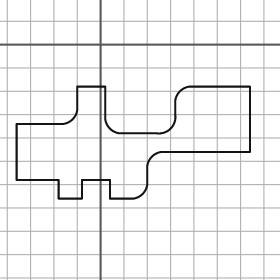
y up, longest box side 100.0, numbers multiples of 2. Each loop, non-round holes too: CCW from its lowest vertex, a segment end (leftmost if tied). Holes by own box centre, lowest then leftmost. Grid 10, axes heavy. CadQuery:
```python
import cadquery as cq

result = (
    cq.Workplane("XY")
    .moveTo(-18.0, -66.0)
    .lineTo(-8.0, -66.0)
    .lineTo(-8.0, -58.0)
    .lineTo(4.0, -58.0)
    .lineTo(4.0, -66.0)
    .lineTo(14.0, -66.0)
    .threePointArc((18.0, -64.0), (20.0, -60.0))
    .lineTo(20.0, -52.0)
    .threePointArc((22.0, -48.0), (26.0, -46.0))
    .lineTo(64.0, -46.0)
    .lineTo(64.0, -18.0)
    .lineTo(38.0, -18.0)
    .threePointArc((34.0, -20.0), (32.0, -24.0))
    .lineTo(32.0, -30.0)
    .threePointArc((30.0, -36.0), (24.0, -38.0))
    .lineTo(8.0, -38.0)
    .threePointArc((4.0, -36.0), (2.0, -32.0))
    .lineTo(2.0, -18.0)
    .lineTo(-10.0, -18.0)
    .lineTo(-10.0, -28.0)
    .threePointArc((-12.0, -32.0), (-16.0, -34.0))
    .lineTo(-36.0, -34.0)
    .lineTo(-36.0, -58.0)
    .lineTo(-18.0, -58.0)
    .close()
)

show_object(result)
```